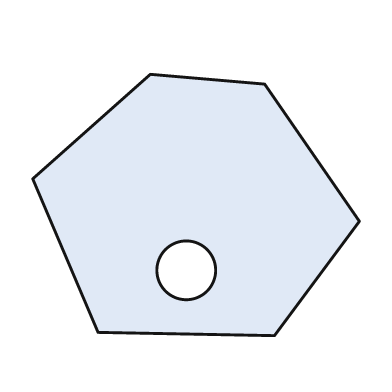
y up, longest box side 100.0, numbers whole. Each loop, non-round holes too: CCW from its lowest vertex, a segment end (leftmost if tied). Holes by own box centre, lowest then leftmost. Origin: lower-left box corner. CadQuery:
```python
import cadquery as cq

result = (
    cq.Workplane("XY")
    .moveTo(74.0, 0.0)
    .lineTo(100.0, 35.0)
    .lineTo(71.0, 77.0)
    .lineTo(36.0, 80.0)
    .lineTo(0.0, 48.0)
    .lineTo(20.0, 1.0)
    .close()
    .moveTo(47.0, 20.0)
    .circle(9.0)
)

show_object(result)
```